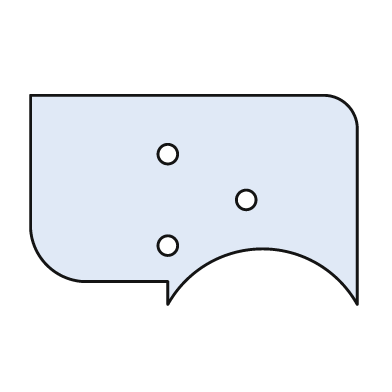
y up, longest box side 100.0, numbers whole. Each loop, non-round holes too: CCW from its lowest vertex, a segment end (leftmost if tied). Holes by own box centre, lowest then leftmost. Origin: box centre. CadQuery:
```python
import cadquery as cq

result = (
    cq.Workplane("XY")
    .moveTo(-8.0, -32.0)
    .threePointArc((21.0, -15.0), (50.0, -32.0))
    .lineTo(50.0, 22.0)
    .threePointArc((47.0, 29.0), (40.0, 32.0))
    .lineTo(-50.0, 32.0)
    .lineTo(-50.0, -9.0)
    .threePointArc((-45.0, -20.0), (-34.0, -25.0))
    .lineTo(-8.0, -25.0)
    .close()
    .moveTo(-8.0, -14.0)
    .circle(3.0)
    .moveTo(16.0, 0.0)
    .circle(3.0)
    .moveTo(-8.0, 14.0)
    .circle(3.0)
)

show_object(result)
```